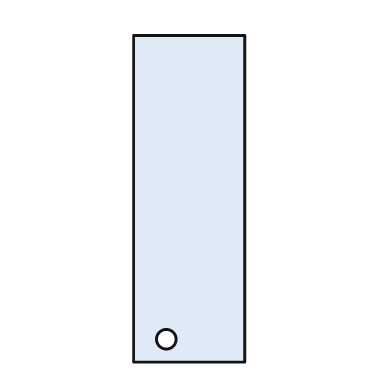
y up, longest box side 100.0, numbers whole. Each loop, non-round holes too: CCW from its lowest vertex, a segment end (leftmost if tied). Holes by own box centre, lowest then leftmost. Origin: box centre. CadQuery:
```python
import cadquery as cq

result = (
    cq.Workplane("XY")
    .moveTo(-17.0, -50.0)
    .lineTo(17.0, -50.0)
    .lineTo(17.0, 50.0)
    .lineTo(-17.0, 50.0)
    .close()
    .moveTo(-7.0, -43.0)
    .circle(3.0)
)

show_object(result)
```